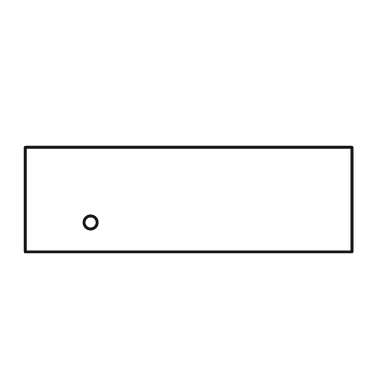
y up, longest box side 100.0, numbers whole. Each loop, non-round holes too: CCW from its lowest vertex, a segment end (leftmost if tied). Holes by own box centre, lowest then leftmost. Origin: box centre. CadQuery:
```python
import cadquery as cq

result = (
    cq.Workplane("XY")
    .moveTo(-50.0, -16.0)
    .lineTo(50.0, -16.0)
    .lineTo(50.0, 16.0)
    .lineTo(-50.0, 16.0)
    .close()
    .moveTo(-30.0, -7.0)
    .circle(2.0)
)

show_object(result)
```